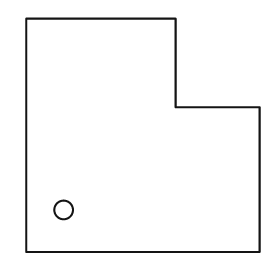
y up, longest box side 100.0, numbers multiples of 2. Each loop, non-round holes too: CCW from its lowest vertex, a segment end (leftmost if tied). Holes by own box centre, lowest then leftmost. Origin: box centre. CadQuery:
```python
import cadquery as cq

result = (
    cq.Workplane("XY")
    .moveTo(-50.0, -50.0)
    .lineTo(50.0, -50.0)
    .lineTo(50.0, 12.0)
    .lineTo(14.0, 12.0)
    .lineTo(14.0, 50.0)
    .lineTo(-50.0, 50.0)
    .close()
    .moveTo(-34.0, -32.0)
    .circle(4.0)
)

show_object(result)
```